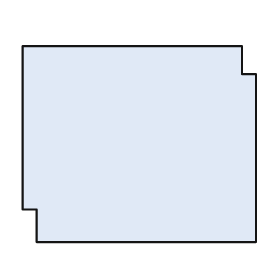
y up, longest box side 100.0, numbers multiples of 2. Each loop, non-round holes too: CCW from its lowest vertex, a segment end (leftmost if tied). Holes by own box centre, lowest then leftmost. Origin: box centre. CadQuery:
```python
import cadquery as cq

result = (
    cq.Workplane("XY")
    .moveTo(-44.0, -42.0)
    .lineTo(50.0, -42.0)
    .lineTo(50.0, 30.0)
    .lineTo(44.0, 30.0)
    .lineTo(44.0, 42.0)
    .lineTo(-50.0, 42.0)
    .lineTo(-50.0, -28.0)
    .lineTo(-44.0, -28.0)
    .close()
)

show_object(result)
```